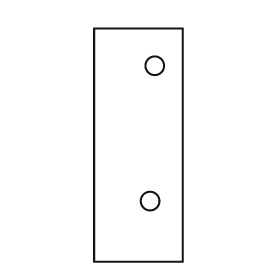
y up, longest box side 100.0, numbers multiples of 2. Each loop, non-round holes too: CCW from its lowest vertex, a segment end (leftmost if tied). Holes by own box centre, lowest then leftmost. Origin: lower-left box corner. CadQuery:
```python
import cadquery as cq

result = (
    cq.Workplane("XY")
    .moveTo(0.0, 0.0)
    .lineTo(38.0, 0.0)
    .lineTo(38.0, 100.0)
    .lineTo(0.0, 100.0)
    .close()
    .moveTo(24.0, 26.0)
    .circle(4.0)
    .moveTo(26.0, 84.0)
    .circle(4.0)
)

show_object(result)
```